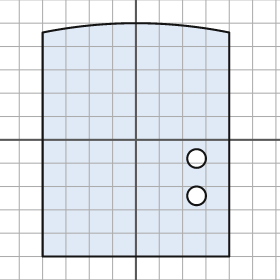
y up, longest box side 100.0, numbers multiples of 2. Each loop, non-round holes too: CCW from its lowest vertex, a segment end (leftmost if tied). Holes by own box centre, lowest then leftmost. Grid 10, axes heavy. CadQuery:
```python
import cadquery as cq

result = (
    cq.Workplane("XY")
    .moveTo(-40.0, -50.0)
    .lineTo(40.0, -50.0)
    .lineTo(40.0, 46.0)
    .threePointArc((0.0, 50.0), (-40.0, 46.0))
    .close()
    .moveTo(26.0, -24.0)
    .circle(4.0)
    .moveTo(26.0, -8.0)
    .circle(4.0)
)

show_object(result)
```